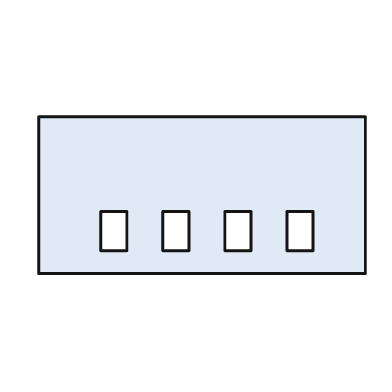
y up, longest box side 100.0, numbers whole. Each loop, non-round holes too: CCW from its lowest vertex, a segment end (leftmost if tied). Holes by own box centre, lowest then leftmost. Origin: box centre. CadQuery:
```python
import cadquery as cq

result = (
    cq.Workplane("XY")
    .moveTo(-50.0, -24.0)
    .lineTo(50.0, -24.0)
    .lineTo(50.0, 24.0)
    .lineTo(-50.0, 24.0)
    .close()
    .moveTo(-31.0, -17.0)
    .lineTo(-23.0, -17.0)
    .lineTo(-23.0, -5.0)
    .lineTo(-31.0, -5.0)
    .close()
    .moveTo(-12.0, -17.0)
    .lineTo(-4.0, -17.0)
    .lineTo(-4.0, -5.0)
    .lineTo(-12.0, -5.0)
    .close()
    .moveTo(7.0, -17.0)
    .lineTo(15.0, -17.0)
    .lineTo(15.0, -5.0)
    .lineTo(7.0, -5.0)
    .close()
    .moveTo(26.0, -17.0)
    .lineTo(34.0, -17.0)
    .lineTo(34.0, -5.0)
    .lineTo(26.0, -5.0)
    .close()
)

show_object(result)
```